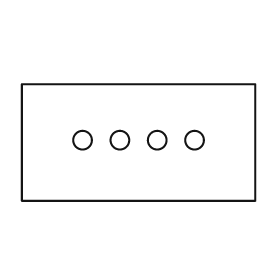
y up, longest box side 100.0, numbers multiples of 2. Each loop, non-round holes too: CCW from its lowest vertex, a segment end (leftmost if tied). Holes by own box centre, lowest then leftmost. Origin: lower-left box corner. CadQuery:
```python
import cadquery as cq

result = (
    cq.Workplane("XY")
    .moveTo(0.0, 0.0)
    .lineTo(100.0, 0.0)
    .lineTo(100.0, 50.0)
    .lineTo(0.0, 50.0)
    .close()
    .moveTo(26.0, 26.0)
    .circle(4.0)
    .moveTo(42.0, 26.0)
    .circle(4.0)
    .moveTo(58.0, 26.0)
    .circle(4.0)
    .moveTo(74.0, 26.0)
    .circle(4.0)
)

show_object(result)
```